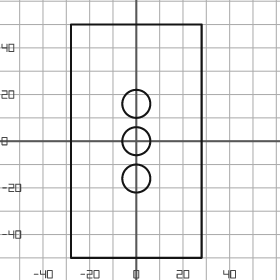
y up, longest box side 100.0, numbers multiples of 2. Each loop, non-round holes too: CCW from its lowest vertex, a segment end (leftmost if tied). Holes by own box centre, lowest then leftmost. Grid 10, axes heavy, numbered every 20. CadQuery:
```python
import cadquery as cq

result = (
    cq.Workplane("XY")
    .moveTo(-28.0, -50.0)
    .lineTo(28.0, -50.0)
    .lineTo(28.0, 50.0)
    .lineTo(-28.0, 50.0)
    .close()
    .moveTo(0.0, -16.0)
    .circle(6.0)
    .moveTo(0.0, 0.0)
    .circle(6.0)
    .moveTo(0.0, 16.0)
    .circle(6.0)
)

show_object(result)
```